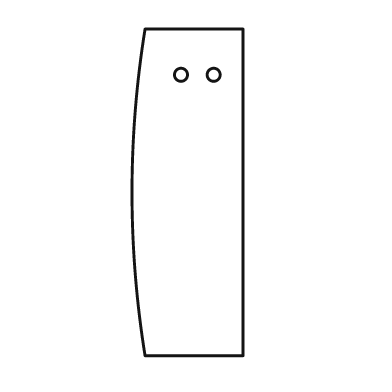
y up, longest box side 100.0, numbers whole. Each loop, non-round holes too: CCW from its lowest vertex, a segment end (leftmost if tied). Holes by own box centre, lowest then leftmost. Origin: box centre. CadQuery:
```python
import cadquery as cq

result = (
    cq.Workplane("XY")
    .moveTo(-13.0, -50.0)
    .lineTo(17.0, -50.0)
    .lineTo(17.0, 50.0)
    .lineTo(-13.0, 50.0)
    .threePointArc((-17.0, 0.0), (-13.0, -50.0))
    .close()
    .moveTo(-2.0, 36.0)
    .circle(2.0)
    .moveTo(8.0, 36.0)
    .circle(2.0)
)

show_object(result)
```